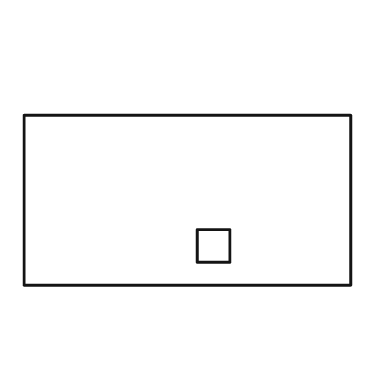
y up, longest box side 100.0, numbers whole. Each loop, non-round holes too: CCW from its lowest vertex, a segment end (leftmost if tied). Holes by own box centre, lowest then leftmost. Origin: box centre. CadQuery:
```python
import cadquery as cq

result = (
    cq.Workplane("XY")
    .moveTo(-50.0, -26.0)
    .lineTo(50.0, -26.0)
    .lineTo(50.0, 26.0)
    .lineTo(-50.0, 26.0)
    .close()
    .moveTo(3.0, -19.0)
    .lineTo(13.0, -19.0)
    .lineTo(13.0, -9.0)
    .lineTo(3.0, -9.0)
    .close()
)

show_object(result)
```